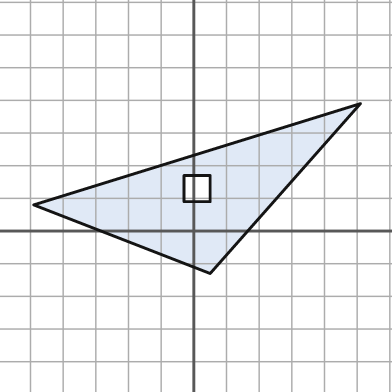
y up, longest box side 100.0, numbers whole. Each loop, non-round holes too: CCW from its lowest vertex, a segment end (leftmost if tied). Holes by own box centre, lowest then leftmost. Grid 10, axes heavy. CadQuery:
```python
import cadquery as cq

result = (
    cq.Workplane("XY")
    .moveTo(5.0, -13.0)
    .lineTo(51.0, 39.0)
    .lineTo(-49.0, 8.0)
    .close()
    .moveTo(-3.0, 9.0)
    .lineTo(5.0, 9.0)
    .lineTo(5.0, 17.0)
    .lineTo(-3.0, 17.0)
    .close()
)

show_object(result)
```